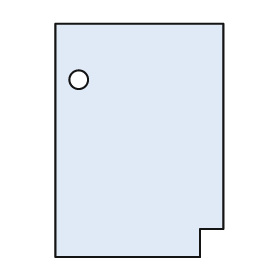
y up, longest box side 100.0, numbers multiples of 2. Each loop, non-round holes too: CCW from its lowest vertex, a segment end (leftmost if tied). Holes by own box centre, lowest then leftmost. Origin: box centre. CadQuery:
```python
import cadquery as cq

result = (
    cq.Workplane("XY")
    .moveTo(-36.0, -50.0)
    .lineTo(26.0, -50.0)
    .lineTo(26.0, -38.0)
    .lineTo(36.0, -38.0)
    .lineTo(36.0, 50.0)
    .lineTo(-36.0, 50.0)
    .close()
    .moveTo(-26.0, 26.0)
    .circle(4.0)
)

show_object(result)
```